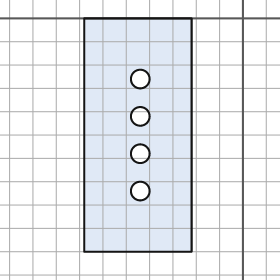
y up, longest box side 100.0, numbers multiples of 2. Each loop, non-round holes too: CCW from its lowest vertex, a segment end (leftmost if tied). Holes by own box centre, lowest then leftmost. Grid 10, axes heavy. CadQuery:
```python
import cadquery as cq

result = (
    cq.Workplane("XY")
    .moveTo(-68.0, -100.0)
    .lineTo(-22.0, -100.0)
    .lineTo(-22.0, 0.0)
    .lineTo(-68.0, 0.0)
    .close()
    .moveTo(-44.0, -74.0)
    .circle(4.0)
    .moveTo(-44.0, -58.0)
    .circle(4.0)
    .moveTo(-44.0, -42.0)
    .circle(4.0)
    .moveTo(-44.0, -26.0)
    .circle(4.0)
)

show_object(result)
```